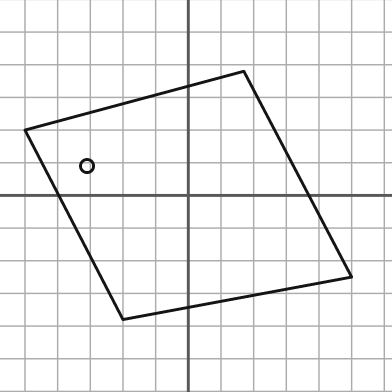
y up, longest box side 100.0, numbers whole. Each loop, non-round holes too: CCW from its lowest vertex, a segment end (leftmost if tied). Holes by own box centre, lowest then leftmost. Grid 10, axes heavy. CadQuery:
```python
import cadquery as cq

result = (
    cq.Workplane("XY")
    .moveTo(-20.0, -38.0)
    .lineTo(50.0, -25.0)
    .lineTo(17.0, 38.0)
    .lineTo(-50.0, 20.0)
    .close()
    .moveTo(-31.0, 9.0)
    .circle(2.0)
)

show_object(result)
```